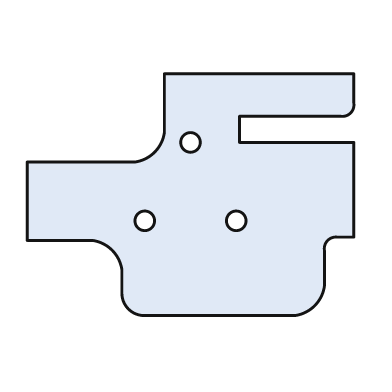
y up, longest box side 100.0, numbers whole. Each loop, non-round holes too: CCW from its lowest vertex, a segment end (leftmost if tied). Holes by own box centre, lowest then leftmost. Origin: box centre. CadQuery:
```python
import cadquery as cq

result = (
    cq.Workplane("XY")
    .moveTo(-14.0, -37.0)
    .lineTo(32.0, -37.0)
    .threePointArc((38.0, -34.0), (41.0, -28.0))
    .lineTo(41.0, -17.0)
    .threePointArc((42.0, -14.0), (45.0, -13.0))
    .lineTo(50.0, -13.0)
    .lineTo(50.0, 16.0)
    .lineTo(15.0, 16.0)
    .lineTo(15.0, 24.0)
    .lineTo(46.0, 24.0)
    .threePointArc((49.0, 25.0), (50.0, 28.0))
    .lineTo(50.0, 37.0)
    .lineTo(-8.0, 37.0)
    .lineTo(-8.0, 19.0)
    .threePointArc((-11.0, 13.0), (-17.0, 10.0))
    .lineTo(-50.0, 10.0)
    .lineTo(-50.0, -14.0)
    .lineTo(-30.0, -14.0)
    .threePointArc((-24.0, -17.0), (-21.0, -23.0))
    .lineTo(-21.0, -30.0)
    .threePointArc((-19.0, -35.0), (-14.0, -37.0))
    .close()
    .moveTo(-14.0, -8.0)
    .circle(3.0)
    .moveTo(14.0, -8.0)
    .circle(3.0)
    .moveTo(0.0, 16.0)
    .circle(3.0)
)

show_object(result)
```